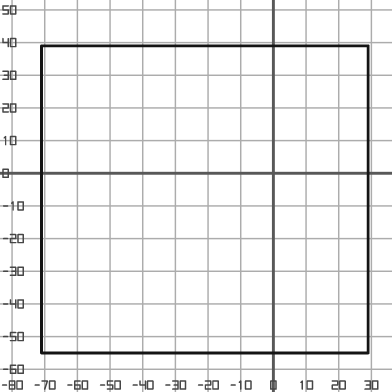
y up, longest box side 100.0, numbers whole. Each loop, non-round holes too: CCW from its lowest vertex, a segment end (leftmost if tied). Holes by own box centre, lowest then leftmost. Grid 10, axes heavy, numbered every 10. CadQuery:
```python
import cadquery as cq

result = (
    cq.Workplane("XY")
    .moveTo(-71.0, -55.0)
    .lineTo(29.0, -55.0)
    .lineTo(29.0, 39.0)
    .lineTo(-71.0, 39.0)
    .close()
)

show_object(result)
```